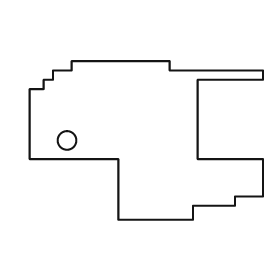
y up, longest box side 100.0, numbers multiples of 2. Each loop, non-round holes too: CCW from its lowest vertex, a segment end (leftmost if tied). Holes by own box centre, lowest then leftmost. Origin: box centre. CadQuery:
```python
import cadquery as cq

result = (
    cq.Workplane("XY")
    .moveTo(-12.0, -34.0)
    .lineTo(20.0, -34.0)
    .lineTo(20.0, -28.0)
    .lineTo(38.0, -28.0)
    .lineTo(38.0, -24.0)
    .lineTo(50.0, -24.0)
    .lineTo(50.0, -8.0)
    .lineTo(22.0, -8.0)
    .lineTo(22.0, 26.0)
    .lineTo(50.0, 26.0)
    .lineTo(50.0, 30.0)
    .lineTo(10.0, 30.0)
    .lineTo(10.0, 34.0)
    .lineTo(-32.0, 34.0)
    .lineTo(-32.0, 30.0)
    .lineTo(-40.0, 30.0)
    .lineTo(-40.0, 26.0)
    .lineTo(-44.0, 26.0)
    .lineTo(-44.0, 22.0)
    .lineTo(-50.0, 22.0)
    .lineTo(-50.0, -8.0)
    .lineTo(-12.0, -8.0)
    .close()
    .moveTo(-34.0, 0.0)
    .circle(4.0)
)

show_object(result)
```